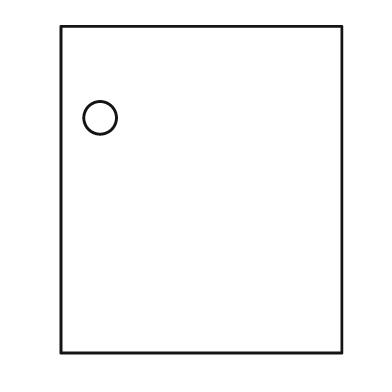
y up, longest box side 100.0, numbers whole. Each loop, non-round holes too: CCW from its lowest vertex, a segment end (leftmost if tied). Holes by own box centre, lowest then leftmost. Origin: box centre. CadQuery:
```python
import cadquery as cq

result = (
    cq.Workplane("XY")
    .moveTo(-43.0, -50.0)
    .lineTo(43.0, -50.0)
    .lineTo(43.0, 50.0)
    .lineTo(-43.0, 50.0)
    .close()
    .moveTo(-31.0, 22.0)
    .circle(5.0)
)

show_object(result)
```